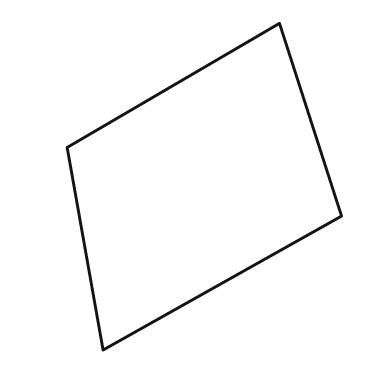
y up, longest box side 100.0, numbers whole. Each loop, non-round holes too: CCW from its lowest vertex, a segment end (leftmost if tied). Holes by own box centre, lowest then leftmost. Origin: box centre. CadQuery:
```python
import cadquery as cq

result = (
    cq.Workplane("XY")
    .moveTo(-31.0, -50.0)
    .lineTo(42.0, -9.0)
    .lineTo(23.0, 50.0)
    .lineTo(-42.0, 12.0)
    .close()
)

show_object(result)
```